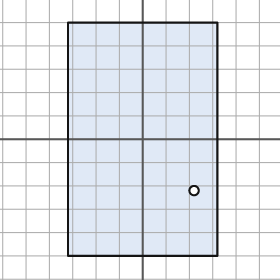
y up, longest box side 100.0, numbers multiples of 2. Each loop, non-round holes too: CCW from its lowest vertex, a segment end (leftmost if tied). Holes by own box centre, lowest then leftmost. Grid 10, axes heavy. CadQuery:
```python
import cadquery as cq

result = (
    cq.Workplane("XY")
    .moveTo(-32.0, -50.0)
    .lineTo(32.0, -50.0)
    .lineTo(32.0, 50.0)
    .lineTo(-32.0, 50.0)
    .close()
    .moveTo(22.0, -22.0)
    .circle(2.0)
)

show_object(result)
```